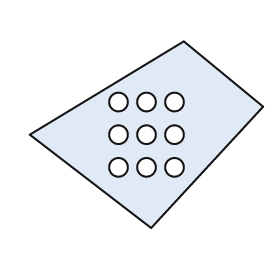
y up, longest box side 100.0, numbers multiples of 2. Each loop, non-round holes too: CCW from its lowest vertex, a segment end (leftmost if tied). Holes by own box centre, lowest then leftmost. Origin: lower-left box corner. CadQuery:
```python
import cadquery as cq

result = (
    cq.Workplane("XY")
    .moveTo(52.0, 0.0)
    .lineTo(100.0, 52.0)
    .lineTo(66.0, 80.0)
    .lineTo(0.0, 40.0)
    .close()
    .moveTo(38.0, 26.0)
    .circle(4.0)
    .moveTo(50.0, 26.0)
    .circle(4.0)
    .moveTo(62.0, 26.0)
    .circle(4.0)
    .moveTo(38.0, 40.0)
    .circle(4.0)
    .moveTo(50.0, 40.0)
    .circle(4.0)
    .moveTo(62.0, 40.0)
    .circle(4.0)
    .moveTo(38.0, 54.0)
    .circle(4.0)
    .moveTo(50.0, 54.0)
    .circle(4.0)
    .moveTo(62.0, 54.0)
    .circle(4.0)
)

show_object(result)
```